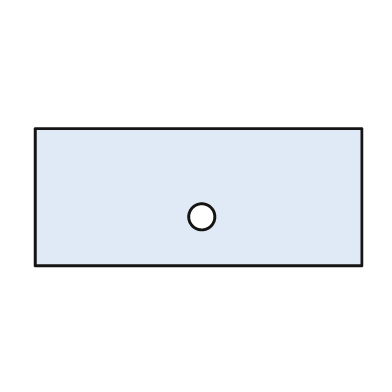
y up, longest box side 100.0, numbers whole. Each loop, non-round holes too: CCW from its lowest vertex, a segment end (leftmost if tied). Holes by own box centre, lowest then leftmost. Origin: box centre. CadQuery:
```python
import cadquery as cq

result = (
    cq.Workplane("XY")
    .moveTo(-50.0, -21.0)
    .lineTo(50.0, -21.0)
    .lineTo(50.0, 21.0)
    .lineTo(-50.0, 21.0)
    .close()
    .moveTo(1.0, -6.0)
    .circle(4.0)
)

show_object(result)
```